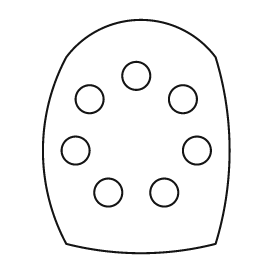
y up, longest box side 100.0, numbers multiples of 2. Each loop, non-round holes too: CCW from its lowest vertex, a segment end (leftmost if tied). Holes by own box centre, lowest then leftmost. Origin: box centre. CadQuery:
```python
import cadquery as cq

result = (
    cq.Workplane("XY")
    .moveTo(-30.0, -46.0)
    .threePointArc((2.0, -50.0), (34.0, -46.0))
    .threePointArc((40.0, -6.0), (34.0, 34.0))
    .threePointArc((2.0, 50.0), (-30.0, 34.0))
    .threePointArc((-40.0, -6.0), (-30.0, -46.0))
    .close()
    .moveTo(-12.0, -24.0)
    .circle(6.0)
    .moveTo(12.0, -24.0)
    .circle(6.0)
    .moveTo(-26.0, -6.0)
    .circle(6.0)
    .moveTo(26.0, -6.0)
    .circle(6.0)
    .moveTo(-20.0, 16.0)
    .circle(6.0)
    .moveTo(20.0, 16.0)
    .circle(6.0)
    .moveTo(0.0, 26.0)
    .circle(6.0)
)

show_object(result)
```